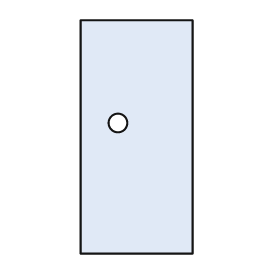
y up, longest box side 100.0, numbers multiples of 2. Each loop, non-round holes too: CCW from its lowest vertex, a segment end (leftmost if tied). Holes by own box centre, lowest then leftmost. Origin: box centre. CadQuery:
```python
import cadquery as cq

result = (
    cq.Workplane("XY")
    .moveTo(-24.0, -50.0)
    .lineTo(24.0, -50.0)
    .lineTo(24.0, 50.0)
    .lineTo(-24.0, 50.0)
    .close()
    .moveTo(-8.0, 6.0)
    .circle(4.0)
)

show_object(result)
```